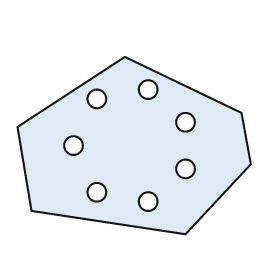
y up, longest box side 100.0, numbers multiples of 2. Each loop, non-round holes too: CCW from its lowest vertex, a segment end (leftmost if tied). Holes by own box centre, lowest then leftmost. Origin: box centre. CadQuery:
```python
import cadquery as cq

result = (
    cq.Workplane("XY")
    .moveTo(22.0, -38.0)
    .lineTo(50.0, -8.0)
    .lineTo(46.0, 14.0)
    .lineTo(-4.0, 38.0)
    .lineTo(-50.0, 8.0)
    .lineTo(-44.0, -28.0)
    .close()
    .moveTo(6.0, -24.0)
    .circle(4.0)
    .moveTo(-16.0, -20.0)
    .circle(4.0)
    .moveTo(22.0, -10.0)
    .circle(4.0)
    .moveTo(-26.0, 0.0)
    .circle(4.0)
    .moveTo(22.0, 10.0)
    .circle(4.0)
    .moveTo(-16.0, 20.0)
    .circle(4.0)
    .moveTo(6.0, 24.0)
    .circle(4.0)
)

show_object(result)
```